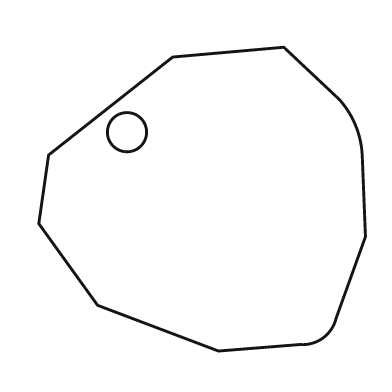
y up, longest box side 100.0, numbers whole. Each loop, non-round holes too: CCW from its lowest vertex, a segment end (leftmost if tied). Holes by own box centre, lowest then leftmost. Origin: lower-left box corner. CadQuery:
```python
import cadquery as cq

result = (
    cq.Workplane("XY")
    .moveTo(55.0, 0.0)
    .lineTo(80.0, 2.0)
    .threePointArc((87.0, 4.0), (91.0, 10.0))
    .lineTo(100.0, 35.0)
    .lineTo(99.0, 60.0)
    .threePointArc((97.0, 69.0), (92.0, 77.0))
    .lineTo(75.0, 93.0)
    .lineTo(41.0, 90.0)
    .lineTo(3.0, 60.0)
    .lineTo(0.0, 39.0)
    .lineTo(18.0, 14.0)
    .close()
    .moveTo(27.0, 67.0)
    .circle(6.0)
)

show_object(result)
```